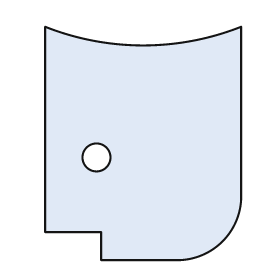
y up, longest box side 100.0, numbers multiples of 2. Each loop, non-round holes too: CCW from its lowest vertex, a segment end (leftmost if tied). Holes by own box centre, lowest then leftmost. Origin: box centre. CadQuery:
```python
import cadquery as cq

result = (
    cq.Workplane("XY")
    .moveTo(-18.0, -50.0)
    .lineTo(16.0, -50.0)
    .threePointArc((34.0, -42.0), (42.0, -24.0))
    .lineTo(42.0, 50.0)
    .threePointArc((0.0, 42.0), (-42.0, 50.0))
    .lineTo(-42.0, -38.0)
    .lineTo(-18.0, -38.0)
    .close()
    .moveTo(-20.0, -6.0)
    .circle(6.0)
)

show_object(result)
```